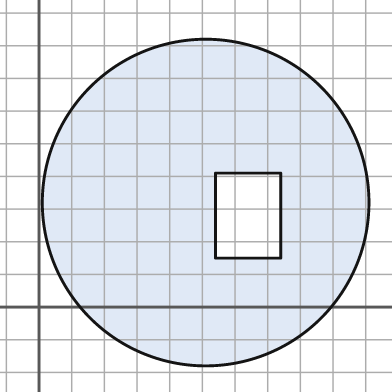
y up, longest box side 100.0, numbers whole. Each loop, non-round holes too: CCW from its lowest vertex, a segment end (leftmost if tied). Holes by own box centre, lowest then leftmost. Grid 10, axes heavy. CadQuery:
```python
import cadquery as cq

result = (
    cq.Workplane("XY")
    .moveTo(51.0, 32.0)
    .circle(50.0)
    .moveTo(54.0, 15.0)
    .lineTo(74.0, 15.0)
    .lineTo(74.0, 41.0)
    .lineTo(54.0, 41.0)
    .close()
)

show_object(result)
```